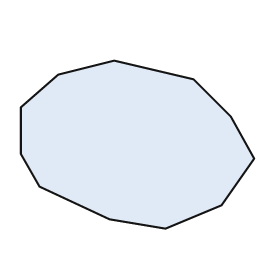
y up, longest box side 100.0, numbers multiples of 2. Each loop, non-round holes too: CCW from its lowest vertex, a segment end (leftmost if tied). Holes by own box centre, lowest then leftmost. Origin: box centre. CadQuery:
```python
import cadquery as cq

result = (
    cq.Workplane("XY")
    .moveTo(12.0, -36.0)
    .lineTo(36.0, -26.0)
    .lineTo(50.0, -6.0)
    .lineTo(40.0, 12.0)
    .lineTo(24.0, 28.0)
    .lineTo(-10.0, 36.0)
    .lineTo(-34.0, 30.0)
    .lineTo(-50.0, 16.0)
    .lineTo(-50.0, -4.0)
    .lineTo(-42.0, -18.0)
    .lineTo(-12.0, -32.0)
    .close()
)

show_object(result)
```